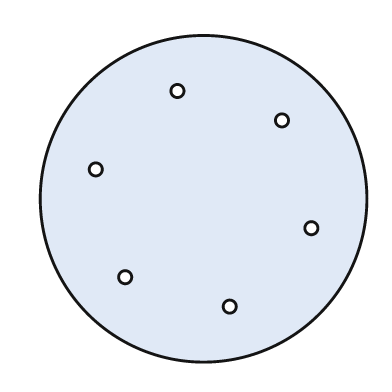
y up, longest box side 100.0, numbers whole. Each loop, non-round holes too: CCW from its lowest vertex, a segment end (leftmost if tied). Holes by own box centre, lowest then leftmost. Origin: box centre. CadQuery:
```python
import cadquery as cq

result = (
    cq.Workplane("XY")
    .moveTo(0.0, 0.0)
    .circle(50.0)
    .moveTo(8.0, -33.0)
    .circle(2.0)
    .moveTo(-24.0, -24.0)
    .circle(2.0)
    .moveTo(33.0, -9.0)
    .circle(2.0)
    .moveTo(-33.0, 9.0)
    .circle(2.0)
    .moveTo(24.0, 24.0)
    .circle(2.0)
    .moveTo(-8.0, 33.0)
    .circle(2.0)
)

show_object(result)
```